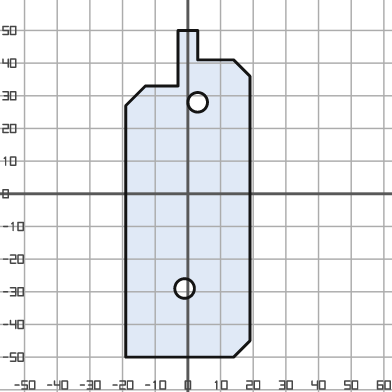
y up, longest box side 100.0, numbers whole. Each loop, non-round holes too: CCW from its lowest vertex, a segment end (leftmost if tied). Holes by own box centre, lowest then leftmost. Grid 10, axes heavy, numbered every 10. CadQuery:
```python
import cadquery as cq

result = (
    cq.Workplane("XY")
    .moveTo(-19.0, -50.0)
    .lineTo(14.0, -50.0)
    .lineTo(19.0, -45.0)
    .lineTo(19.0, 36.0)
    .lineTo(14.0, 41.0)
    .lineTo(3.0, 41.0)
    .lineTo(3.0, 50.0)
    .lineTo(-3.0, 50.0)
    .lineTo(-3.0, 33.0)
    .lineTo(-13.0, 33.0)
    .lineTo(-19.0, 27.0)
    .close()
    .moveTo(-1.0, -29.0)
    .circle(3.0)
    .moveTo(3.0, 28.0)
    .circle(3.0)
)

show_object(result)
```